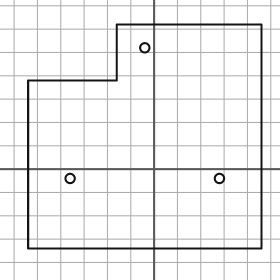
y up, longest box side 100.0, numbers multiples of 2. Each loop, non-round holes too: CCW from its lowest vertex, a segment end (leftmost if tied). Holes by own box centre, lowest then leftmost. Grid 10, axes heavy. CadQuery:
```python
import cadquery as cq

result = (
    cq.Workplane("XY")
    .moveTo(-54.0, -34.0)
    .lineTo(46.0, -34.0)
    .lineTo(46.0, 62.0)
    .lineTo(-16.0, 62.0)
    .lineTo(-16.0, 38.0)
    .lineTo(-54.0, 38.0)
    .close()
    .moveTo(-36.0, -4.0)
    .circle(2.0)
    .moveTo(28.0, -4.0)
    .circle(2.0)
    .moveTo(-4.0, 52.0)
    .circle(2.0)
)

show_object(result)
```